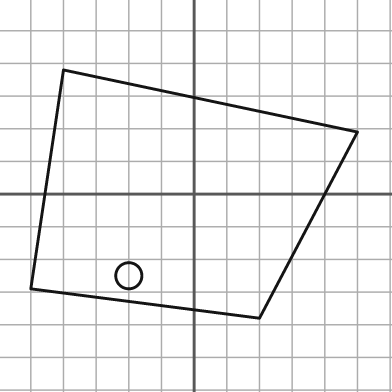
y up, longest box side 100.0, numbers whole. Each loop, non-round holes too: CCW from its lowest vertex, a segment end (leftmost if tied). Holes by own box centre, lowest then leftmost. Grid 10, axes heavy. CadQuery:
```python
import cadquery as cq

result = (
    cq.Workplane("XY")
    .moveTo(20.0, -38.0)
    .lineTo(50.0, 19.0)
    .lineTo(-40.0, 38.0)
    .lineTo(-50.0, -29.0)
    .close()
    .moveTo(-20.0, -25.0)
    .circle(4.0)
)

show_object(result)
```